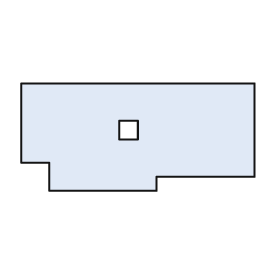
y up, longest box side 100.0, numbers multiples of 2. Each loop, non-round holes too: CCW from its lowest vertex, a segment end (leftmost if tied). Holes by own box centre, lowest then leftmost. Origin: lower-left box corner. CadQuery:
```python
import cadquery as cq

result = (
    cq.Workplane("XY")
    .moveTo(12.0, 0.0)
    .lineTo(58.0, 0.0)
    .lineTo(58.0, 6.0)
    .lineTo(100.0, 6.0)
    .lineTo(100.0, 46.0)
    .lineTo(0.0, 46.0)
    .lineTo(0.0, 12.0)
    .lineTo(12.0, 12.0)
    .close()
    .moveTo(42.0, 22.0)
    .lineTo(50.0, 22.0)
    .lineTo(50.0, 30.0)
    .lineTo(42.0, 30.0)
    .close()
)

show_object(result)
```